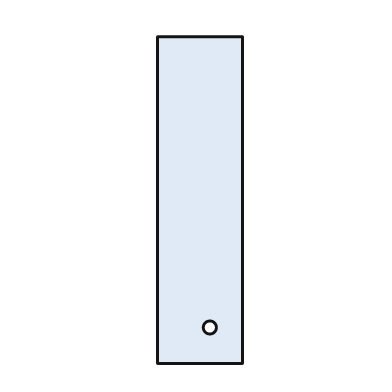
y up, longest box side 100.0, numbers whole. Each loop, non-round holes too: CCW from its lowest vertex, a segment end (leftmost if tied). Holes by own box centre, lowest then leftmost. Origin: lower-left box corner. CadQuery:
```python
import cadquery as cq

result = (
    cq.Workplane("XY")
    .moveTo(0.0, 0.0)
    .lineTo(26.0, 0.0)
    .lineTo(26.0, 100.0)
    .lineTo(0.0, 100.0)
    .close()
    .moveTo(16.0, 11.0)
    .circle(2.0)
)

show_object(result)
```